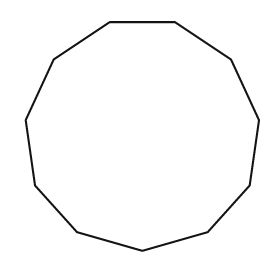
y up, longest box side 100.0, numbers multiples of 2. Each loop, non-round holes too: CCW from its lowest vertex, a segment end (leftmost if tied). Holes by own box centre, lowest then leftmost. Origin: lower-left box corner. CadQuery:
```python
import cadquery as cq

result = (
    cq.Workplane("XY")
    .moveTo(50.0, 0.0)
    .lineTo(78.0, 8.0)
    .lineTo(96.0, 28.0)
    .lineTo(100.0, 56.0)
    .lineTo(88.0, 82.0)
    .lineTo(64.0, 98.0)
    .lineTo(36.0, 98.0)
    .lineTo(12.0, 82.0)
    .lineTo(0.0, 56.0)
    .lineTo(4.0, 28.0)
    .lineTo(22.0, 8.0)
    .close()
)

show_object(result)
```